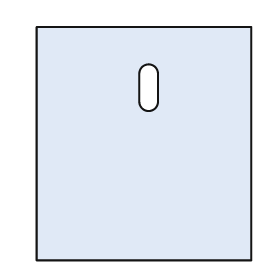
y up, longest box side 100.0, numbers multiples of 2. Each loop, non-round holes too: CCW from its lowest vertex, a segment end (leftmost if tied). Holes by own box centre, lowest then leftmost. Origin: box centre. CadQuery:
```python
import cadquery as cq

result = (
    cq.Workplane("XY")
    .moveTo(-46.0, -50.0)
    .lineTo(46.0, -50.0)
    .lineTo(46.0, 50.0)
    .lineTo(-46.0, 50.0)
    .close()
    .moveTo(-2.0, 18.0)
    .threePointArc((2.0, 14.0), (6.0, 18.0))
    .lineTo(6.0, 30.0)
    .threePointArc((2.0, 34.0), (-2.0, 30.0))
    .close()
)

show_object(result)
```